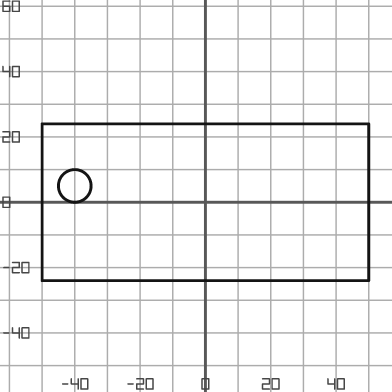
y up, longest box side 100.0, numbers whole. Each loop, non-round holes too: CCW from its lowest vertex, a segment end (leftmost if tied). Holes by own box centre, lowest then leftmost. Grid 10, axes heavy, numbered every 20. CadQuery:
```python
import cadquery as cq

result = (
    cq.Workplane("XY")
    .moveTo(-50.0, -24.0)
    .lineTo(50.0, -24.0)
    .lineTo(50.0, 24.0)
    .lineTo(-50.0, 24.0)
    .close()
    .moveTo(-40.0, 5.0)
    .circle(5.0)
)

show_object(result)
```